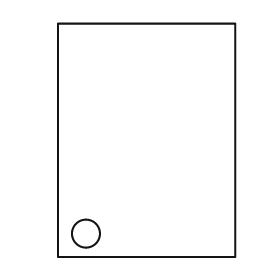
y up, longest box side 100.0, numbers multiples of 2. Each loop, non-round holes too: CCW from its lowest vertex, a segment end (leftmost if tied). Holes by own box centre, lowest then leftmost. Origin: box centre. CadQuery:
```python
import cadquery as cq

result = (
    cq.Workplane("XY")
    .moveTo(-38.0, -50.0)
    .lineTo(38.0, -50.0)
    .lineTo(38.0, 50.0)
    .lineTo(-38.0, 50.0)
    .close()
    .moveTo(-26.0, -40.0)
    .circle(6.0)
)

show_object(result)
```